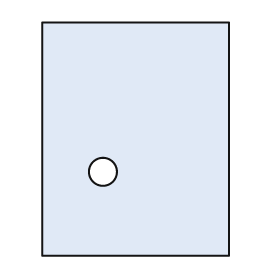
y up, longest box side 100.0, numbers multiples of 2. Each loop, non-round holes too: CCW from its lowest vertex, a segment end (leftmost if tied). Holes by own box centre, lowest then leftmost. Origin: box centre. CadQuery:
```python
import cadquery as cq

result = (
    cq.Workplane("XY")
    .moveTo(-40.0, -50.0)
    .lineTo(40.0, -50.0)
    .lineTo(40.0, 50.0)
    .lineTo(-40.0, 50.0)
    .close()
    .moveTo(-14.0, -14.0)
    .circle(6.0)
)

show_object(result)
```